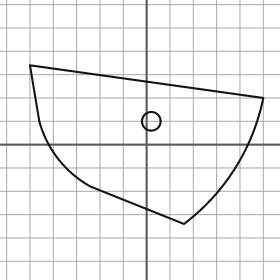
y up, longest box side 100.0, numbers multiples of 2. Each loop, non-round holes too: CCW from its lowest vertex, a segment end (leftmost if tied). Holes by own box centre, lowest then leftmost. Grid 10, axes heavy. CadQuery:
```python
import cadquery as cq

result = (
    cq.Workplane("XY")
    .moveTo(16.0, -34.0)
    .threePointArc((38.0, -10.0), (50.0, 20.0))
    .lineTo(-50.0, 34.0)
    .lineTo(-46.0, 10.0)
    .threePointArc((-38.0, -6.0), (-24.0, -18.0))
    .close()
    .moveTo(2.0, 10.0)
    .circle(4.0)
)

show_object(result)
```